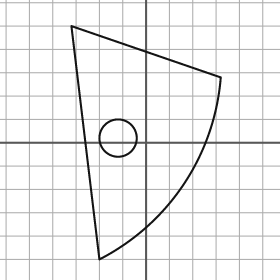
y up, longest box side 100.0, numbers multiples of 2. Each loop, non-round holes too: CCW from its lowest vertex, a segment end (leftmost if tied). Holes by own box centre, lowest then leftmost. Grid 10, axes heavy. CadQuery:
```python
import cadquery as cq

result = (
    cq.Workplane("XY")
    .moveTo(-20.0, -50.0)
    .threePointArc((16.0, -18.0), (32.0, 28.0))
    .lineTo(-32.0, 50.0)
    .close()
    .moveTo(-12.0, 2.0)
    .circle(8.0)
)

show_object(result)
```